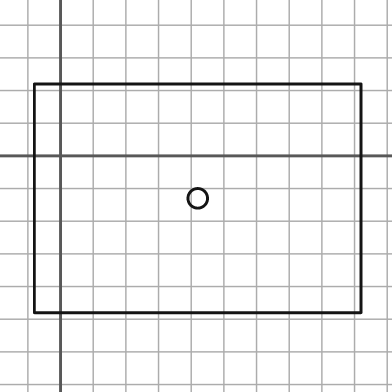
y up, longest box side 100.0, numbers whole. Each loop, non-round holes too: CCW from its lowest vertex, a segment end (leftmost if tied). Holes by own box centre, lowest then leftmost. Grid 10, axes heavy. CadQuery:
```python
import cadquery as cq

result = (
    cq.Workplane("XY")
    .moveTo(-8.0, -48.0)
    .lineTo(92.0, -48.0)
    .lineTo(92.0, 22.0)
    .lineTo(-8.0, 22.0)
    .close()
    .moveTo(42.0, -13.0)
    .circle(3.0)
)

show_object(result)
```